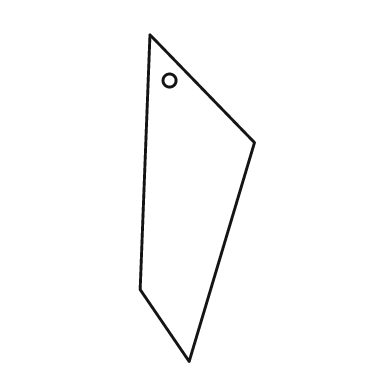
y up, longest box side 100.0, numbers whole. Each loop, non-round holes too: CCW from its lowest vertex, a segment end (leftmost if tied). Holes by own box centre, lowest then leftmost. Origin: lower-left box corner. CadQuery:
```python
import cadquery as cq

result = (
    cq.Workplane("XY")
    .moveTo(15.0, 0.0)
    .lineTo(35.0, 67.0)
    .lineTo(3.0, 100.0)
    .lineTo(0.0, 22.0)
    .close()
    .moveTo(9.0, 86.0)
    .circle(2.0)
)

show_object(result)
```